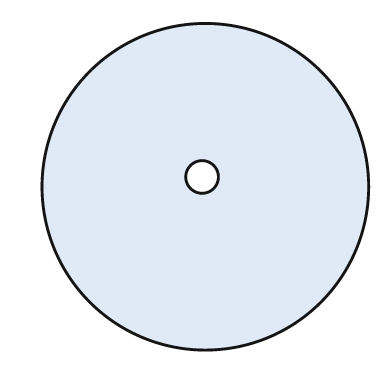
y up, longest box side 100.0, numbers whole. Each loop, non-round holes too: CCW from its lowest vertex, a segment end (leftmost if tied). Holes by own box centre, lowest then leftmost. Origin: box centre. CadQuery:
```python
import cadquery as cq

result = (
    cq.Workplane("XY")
    .moveTo(0.0, 0.0)
    .circle(50.0)
    .moveTo(-1.0, 3.0)
    .circle(5.0)
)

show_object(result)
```